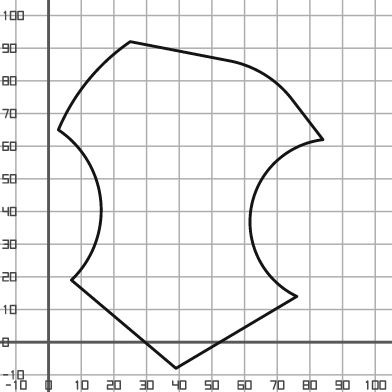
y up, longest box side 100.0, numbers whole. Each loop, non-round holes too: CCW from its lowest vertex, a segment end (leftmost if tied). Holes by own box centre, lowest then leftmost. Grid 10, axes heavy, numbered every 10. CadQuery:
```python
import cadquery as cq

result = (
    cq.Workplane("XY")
    .moveTo(39.0, -8.0)
    .lineTo(76.0, 14.0)
    .threePointArc((62.0, 41.0), (84.0, 62.0))
    .lineTo(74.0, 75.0)
    .threePointArc((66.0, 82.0), (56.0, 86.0))
    .lineTo(25.0, 92.0)
    .threePointArc((12.0, 80.0), (3.0, 65.0))
    .threePointArc((16.0, 43.0), (7.0, 19.0))
    .close()
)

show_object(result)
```